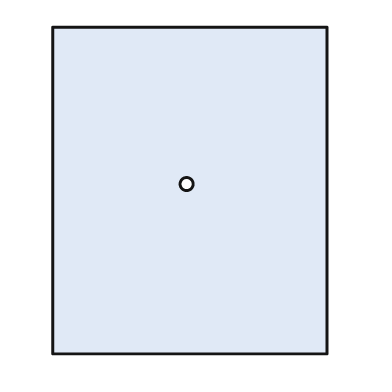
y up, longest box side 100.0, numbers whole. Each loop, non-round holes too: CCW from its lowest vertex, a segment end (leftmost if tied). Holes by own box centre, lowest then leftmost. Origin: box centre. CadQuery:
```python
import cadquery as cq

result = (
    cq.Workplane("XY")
    .moveTo(-42.0, -50.0)
    .lineTo(42.0, -50.0)
    .lineTo(42.0, 50.0)
    .lineTo(-42.0, 50.0)
    .close()
    .moveTo(-1.0, 2.0)
    .circle(2.0)
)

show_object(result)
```